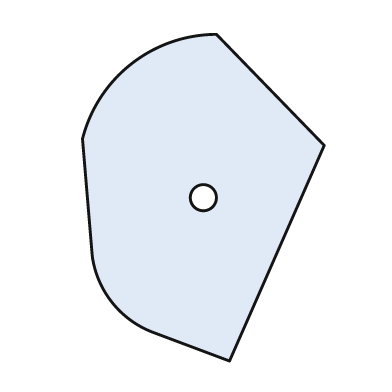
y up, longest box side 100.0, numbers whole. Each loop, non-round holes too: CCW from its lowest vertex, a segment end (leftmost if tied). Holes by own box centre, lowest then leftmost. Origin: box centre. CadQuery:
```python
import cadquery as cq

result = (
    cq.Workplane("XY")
    .moveTo(8.0, -50.0)
    .lineTo(37.0, 16.0)
    .lineTo(4.0, 50.0)
    .threePointArc((-22.0, 41.0), (-37.0, 18.0))
    .lineTo(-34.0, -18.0)
    .threePointArc((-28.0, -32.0), (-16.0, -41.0))
    .close()
    .moveTo(0.0, 0.0)
    .circle(4.0)
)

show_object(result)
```